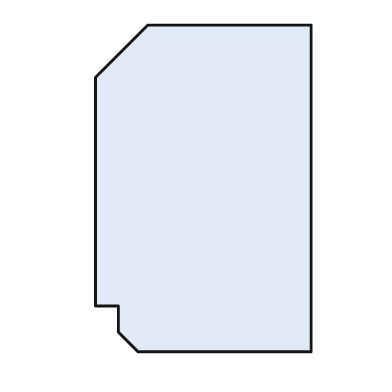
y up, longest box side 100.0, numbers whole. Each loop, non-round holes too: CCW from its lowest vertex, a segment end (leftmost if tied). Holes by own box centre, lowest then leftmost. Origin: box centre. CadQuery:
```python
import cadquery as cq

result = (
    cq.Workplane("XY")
    .moveTo(-20.0, -50.0)
    .lineTo(33.0, -50.0)
    .lineTo(33.0, 50.0)
    .lineTo(-17.0, 50.0)
    .lineTo(-33.0, 34.0)
    .lineTo(-33.0, -36.0)
    .lineTo(-26.0, -36.0)
    .lineTo(-26.0, -44.0)
    .close()
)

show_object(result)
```